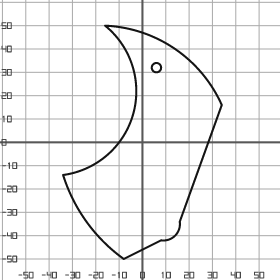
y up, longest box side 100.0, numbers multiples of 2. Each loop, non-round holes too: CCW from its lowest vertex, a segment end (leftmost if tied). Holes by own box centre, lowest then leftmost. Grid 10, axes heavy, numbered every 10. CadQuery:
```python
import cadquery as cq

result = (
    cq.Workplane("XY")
    .moveTo(-8.0, -50.0)
    .lineTo(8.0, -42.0)
    .threePointArc((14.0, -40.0), (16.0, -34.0))
    .lineTo(34.0, 16.0)
    .threePointArc((14.0, 40.0), (-16.0, 50.0))
    .threePointArc((-4.0, 12.0), (-34.0, -14.0))
    .threePointArc((-24.0, -34.0), (-8.0, -50.0))
    .close()
    .moveTo(6.0, 32.0)
    .circle(2.0)
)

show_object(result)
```